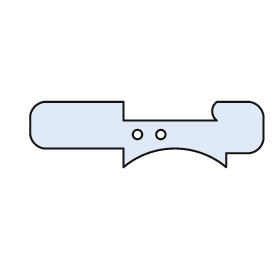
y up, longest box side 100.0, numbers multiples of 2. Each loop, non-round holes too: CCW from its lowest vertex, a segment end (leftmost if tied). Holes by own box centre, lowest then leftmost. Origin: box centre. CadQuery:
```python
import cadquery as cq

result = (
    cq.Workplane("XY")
    .moveTo(-10.0, -14.0)
    .threePointArc((12.0, -6.0), (34.0, -14.0))
    .lineTo(34.0, -8.0)
    .lineTo(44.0, -8.0)
    .threePointArc((48.0, -6.0), (50.0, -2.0))
    .lineTo(50.0, 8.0)
    .threePointArc((48.0, 12.0), (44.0, 14.0))
    .lineTo(30.0, 14.0)
    .threePointArc((28.0, 10.0), (30.0, 6.0))
    .lineTo(-10.0, 6.0)
    .lineTo(-10.0, 14.0)
    .lineTo(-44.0, 14.0)
    .threePointArc((-48.0, 12.0), (-50.0, 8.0))
    .lineTo(-50.0, 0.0)
    .threePointArc((-48.0, -4.0), (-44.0, -6.0))
    .lineTo(-10.0, -6.0)
    .close()
    .moveTo(-4.0, 0.0)
    .circle(2.0)
    .moveTo(6.0, 0.0)
    .circle(2.0)
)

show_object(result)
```